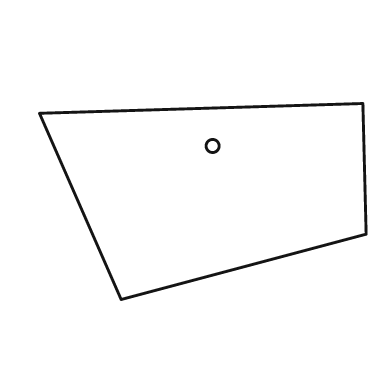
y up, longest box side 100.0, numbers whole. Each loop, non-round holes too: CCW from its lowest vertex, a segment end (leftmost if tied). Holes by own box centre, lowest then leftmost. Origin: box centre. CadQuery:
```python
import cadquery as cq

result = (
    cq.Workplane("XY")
    .moveTo(-25.0, -30.0)
    .lineTo(50.0, -10.0)
    .lineTo(49.0, 30.0)
    .lineTo(-50.0, 27.0)
    .close()
    .moveTo(3.0, 17.0)
    .circle(2.0)
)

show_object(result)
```